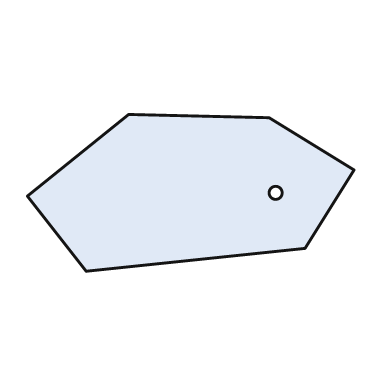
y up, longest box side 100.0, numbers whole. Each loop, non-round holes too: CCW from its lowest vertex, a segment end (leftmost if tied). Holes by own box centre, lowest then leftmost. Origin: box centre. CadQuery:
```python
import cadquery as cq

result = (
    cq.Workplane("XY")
    .moveTo(-32.0, -24.0)
    .lineTo(35.0, -17.0)
    .lineTo(50.0, 7.0)
    .lineTo(24.0, 23.0)
    .lineTo(-19.0, 24.0)
    .lineTo(-50.0, -1.0)
    .close()
    .moveTo(26.0, 0.0)
    .circle(2.0)
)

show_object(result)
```